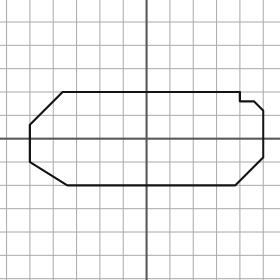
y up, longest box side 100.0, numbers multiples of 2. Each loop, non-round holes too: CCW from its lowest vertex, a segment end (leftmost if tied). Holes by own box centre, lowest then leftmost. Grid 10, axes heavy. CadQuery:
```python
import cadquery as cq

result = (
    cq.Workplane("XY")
    .moveTo(-34.0, -20.0)
    .lineTo(38.0, -20.0)
    .lineTo(50.0, -8.0)
    .lineTo(50.0, 12.0)
    .lineTo(46.0, 16.0)
    .lineTo(40.0, 16.0)
    .lineTo(40.0, 20.0)
    .lineTo(-36.0, 20.0)
    .lineTo(-50.0, 6.0)
    .lineTo(-50.0, -10.0)
    .close()
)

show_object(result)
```